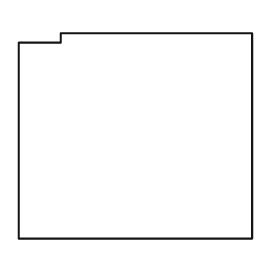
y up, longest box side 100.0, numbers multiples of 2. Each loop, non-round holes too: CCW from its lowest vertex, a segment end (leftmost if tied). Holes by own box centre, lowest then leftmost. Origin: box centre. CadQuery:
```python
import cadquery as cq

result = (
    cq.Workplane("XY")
    .moveTo(-50.0, -44.0)
    .lineTo(50.0, -44.0)
    .lineTo(50.0, 44.0)
    .lineTo(-32.0, 44.0)
    .lineTo(-32.0, 40.0)
    .lineTo(-50.0, 40.0)
    .close()
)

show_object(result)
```